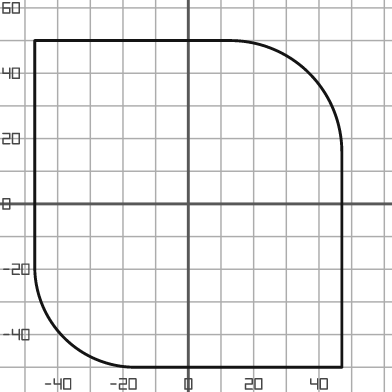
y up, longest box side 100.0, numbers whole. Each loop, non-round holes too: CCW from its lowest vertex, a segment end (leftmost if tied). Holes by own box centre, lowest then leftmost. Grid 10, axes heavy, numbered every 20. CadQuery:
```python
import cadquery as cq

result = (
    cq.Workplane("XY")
    .moveTo(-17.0, -50.0)
    .lineTo(47.0, -50.0)
    .lineTo(47.0, 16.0)
    .threePointArc((37.0, 40.0), (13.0, 50.0))
    .lineTo(-47.0, 50.0)
    .lineTo(-47.0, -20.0)
    .threePointArc((-38.0, -41.0), (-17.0, -50.0))
    .close()
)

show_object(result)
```